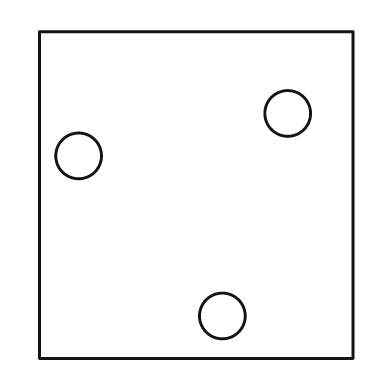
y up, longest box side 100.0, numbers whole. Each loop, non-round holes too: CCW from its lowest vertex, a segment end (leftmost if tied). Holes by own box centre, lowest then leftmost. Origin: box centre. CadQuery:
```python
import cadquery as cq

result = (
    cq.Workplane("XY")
    .moveTo(-48.0, -50.0)
    .lineTo(48.0, -50.0)
    .lineTo(48.0, 50.0)
    .lineTo(-48.0, 50.0)
    .close()
    .moveTo(8.0, -37.0)
    .circle(7.0)
    .moveTo(-36.0, 12.0)
    .circle(7.0)
    .moveTo(28.0, 25.0)
    .circle(7.0)
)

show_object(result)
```